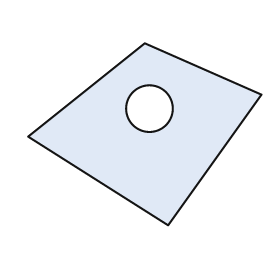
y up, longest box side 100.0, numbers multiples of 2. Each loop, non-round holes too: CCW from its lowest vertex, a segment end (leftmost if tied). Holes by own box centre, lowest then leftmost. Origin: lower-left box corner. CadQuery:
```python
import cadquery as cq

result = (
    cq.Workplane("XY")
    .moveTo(60.0, 0.0)
    .lineTo(100.0, 56.0)
    .lineTo(50.0, 78.0)
    .lineTo(0.0, 38.0)
    .close()
    .moveTo(52.0, 50.0)
    .circle(10.0)
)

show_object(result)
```